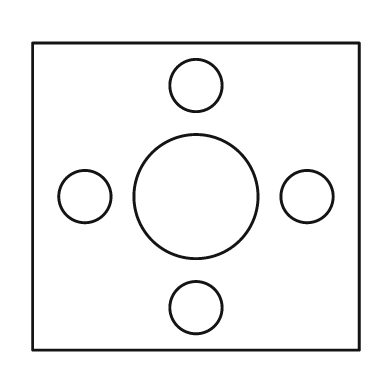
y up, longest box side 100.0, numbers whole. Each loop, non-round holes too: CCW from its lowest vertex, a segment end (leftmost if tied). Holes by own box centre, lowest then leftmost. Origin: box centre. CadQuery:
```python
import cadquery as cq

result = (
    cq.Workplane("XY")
    .moveTo(-50.0, -47.0)
    .lineTo(50.0, -47.0)
    .lineTo(50.0, 47.0)
    .lineTo(-50.0, 47.0)
    .close()
    .moveTo(0.0, -34.0)
    .circle(8.0)
    .moveTo(-34.0, 0.0)
    .circle(8.0)
    .moveTo(0.0, 0.0)
    .circle(19.0)
    .moveTo(34.0, 0.0)
    .circle(8.0)
    .moveTo(0.0, 34.0)
    .circle(8.0)
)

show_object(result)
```